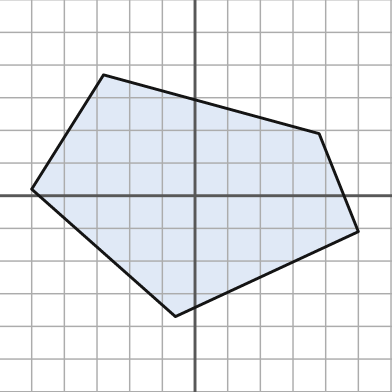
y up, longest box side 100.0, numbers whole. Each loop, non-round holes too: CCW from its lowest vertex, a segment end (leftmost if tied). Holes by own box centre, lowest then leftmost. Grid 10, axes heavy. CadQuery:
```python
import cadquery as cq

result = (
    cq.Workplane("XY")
    .moveTo(-6.0, -37.0)
    .lineTo(50.0, -11.0)
    .lineTo(38.0, 19.0)
    .lineTo(-28.0, 37.0)
    .lineTo(-50.0, 2.0)
    .close()
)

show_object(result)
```